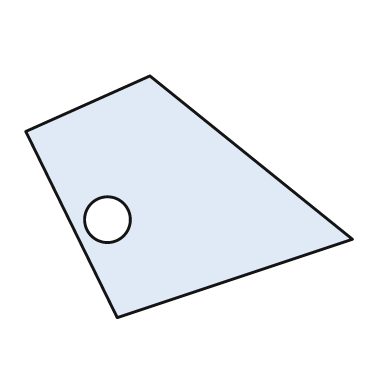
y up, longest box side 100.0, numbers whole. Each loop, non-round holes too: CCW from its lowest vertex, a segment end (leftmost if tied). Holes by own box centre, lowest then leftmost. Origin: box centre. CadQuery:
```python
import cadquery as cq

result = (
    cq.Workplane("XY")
    .moveTo(-22.0, -37.0)
    .lineTo(50.0, -13.0)
    .lineTo(-12.0, 37.0)
    .lineTo(-50.0, 20.0)
    .close()
    .moveTo(-25.0, -7.0)
    .circle(7.0)
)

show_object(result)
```